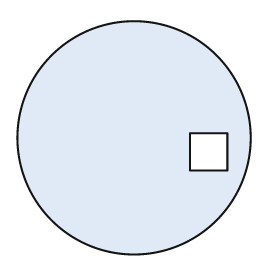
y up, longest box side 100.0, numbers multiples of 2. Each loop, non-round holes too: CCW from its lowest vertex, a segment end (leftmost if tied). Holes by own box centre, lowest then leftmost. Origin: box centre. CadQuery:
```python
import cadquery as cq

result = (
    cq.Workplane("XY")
    .moveTo(0.0, 0.0)
    .circle(50.0)
    .moveTo(24.0, -14.0)
    .lineTo(40.0, -14.0)
    .lineTo(40.0, 2.0)
    .lineTo(24.0, 2.0)
    .close()
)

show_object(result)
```